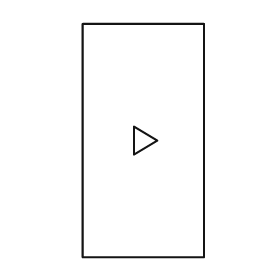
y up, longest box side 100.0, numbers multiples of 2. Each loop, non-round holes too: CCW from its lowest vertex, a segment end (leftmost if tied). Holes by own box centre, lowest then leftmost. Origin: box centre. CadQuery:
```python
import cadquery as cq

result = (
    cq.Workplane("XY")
    .moveTo(-26.0, -50.0)
    .lineTo(26.0, -50.0)
    .lineTo(26.0, 50.0)
    .lineTo(-26.0, 50.0)
    .close()
    .moveTo(-4.0, -6.0)
    .lineTo(6.0, 0.0)
    .lineTo(-4.0, 6.0)
    .close()
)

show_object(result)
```